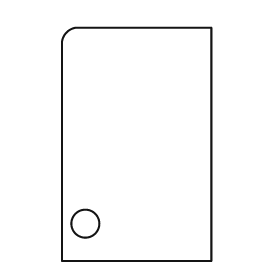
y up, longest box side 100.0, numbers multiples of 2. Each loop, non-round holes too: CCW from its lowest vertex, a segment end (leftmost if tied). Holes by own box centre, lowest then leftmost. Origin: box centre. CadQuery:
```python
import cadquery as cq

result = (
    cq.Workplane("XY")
    .moveTo(-32.0, -50.0)
    .lineTo(32.0, -50.0)
    .lineTo(32.0, 50.0)
    .lineTo(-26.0, 50.0)
    .threePointArc((-30.0, 48.0), (-32.0, 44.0))
    .close()
    .moveTo(-22.0, -34.0)
    .circle(6.0)
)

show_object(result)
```